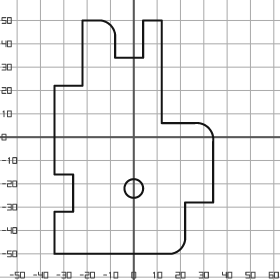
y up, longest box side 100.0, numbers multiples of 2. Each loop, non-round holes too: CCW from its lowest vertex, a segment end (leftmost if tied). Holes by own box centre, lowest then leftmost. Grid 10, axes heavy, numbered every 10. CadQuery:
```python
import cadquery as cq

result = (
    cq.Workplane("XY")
    .moveTo(-34.0, -50.0)
    .lineTo(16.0, -50.0)
    .threePointArc((20.0, -48.0), (22.0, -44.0))
    .lineTo(22.0, -28.0)
    .lineTo(34.0, -28.0)
    .lineTo(34.0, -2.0)
    .threePointArc((32.0, 4.0), (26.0, 6.0))
    .lineTo(12.0, 6.0)
    .lineTo(12.0, 50.0)
    .lineTo(4.0, 50.0)
    .lineTo(4.0, 34.0)
    .lineTo(-8.0, 34.0)
    .lineTo(-8.0, 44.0)
    .threePointArc((-10.0, 48.0), (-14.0, 50.0))
    .lineTo(-22.0, 50.0)
    .lineTo(-22.0, 22.0)
    .lineTo(-34.0, 22.0)
    .lineTo(-34.0, -16.0)
    .lineTo(-26.0, -16.0)
    .lineTo(-26.0, -32.0)
    .lineTo(-34.0, -32.0)
    .close()
    .moveTo(0.0, -22.0)
    .circle(4.0)
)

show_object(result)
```